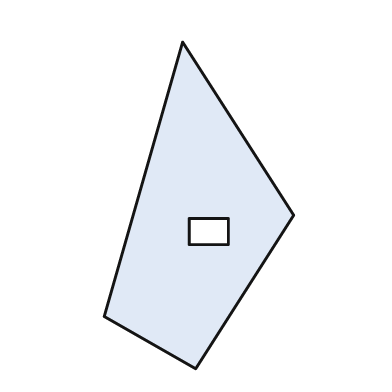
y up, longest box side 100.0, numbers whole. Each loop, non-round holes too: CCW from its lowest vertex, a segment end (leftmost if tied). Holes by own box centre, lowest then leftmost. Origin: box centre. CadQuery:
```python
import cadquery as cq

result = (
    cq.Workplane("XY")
    .moveTo(-1.0, -50.0)
    .lineTo(29.0, -3.0)
    .lineTo(-5.0, 50.0)
    .lineTo(-29.0, -34.0)
    .close()
    .moveTo(-3.0, -12.0)
    .lineTo(9.0, -12.0)
    .lineTo(9.0, -4.0)
    .lineTo(-3.0, -4.0)
    .close()
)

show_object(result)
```